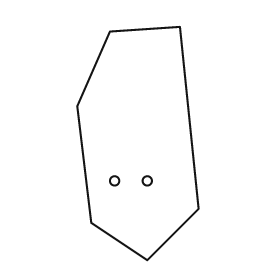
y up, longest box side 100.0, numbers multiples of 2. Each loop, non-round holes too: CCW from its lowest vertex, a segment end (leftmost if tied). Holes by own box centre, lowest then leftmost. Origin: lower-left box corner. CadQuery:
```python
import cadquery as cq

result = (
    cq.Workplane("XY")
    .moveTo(30.0, 0.0)
    .lineTo(52.0, 22.0)
    .lineTo(44.0, 100.0)
    .lineTo(14.0, 98.0)
    .lineTo(0.0, 66.0)
    .lineTo(6.0, 16.0)
    .close()
    .moveTo(16.0, 34.0)
    .circle(2.0)
    .moveTo(30.0, 34.0)
    .circle(2.0)
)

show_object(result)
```